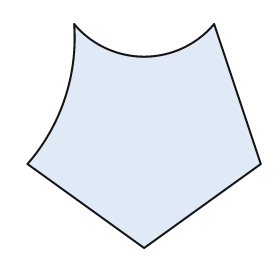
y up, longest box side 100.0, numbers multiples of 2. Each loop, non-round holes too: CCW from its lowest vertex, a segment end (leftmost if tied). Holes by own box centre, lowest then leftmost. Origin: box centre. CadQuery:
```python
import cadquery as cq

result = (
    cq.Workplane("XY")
    .moveTo(0.0, -48.0)
    .lineTo(50.0, -12.0)
    .lineTo(30.0, 48.0)
    .threePointArc((0.0, 34.0), (-30.0, 48.0))
    .threePointArc((-34.0, 16.0), (-50.0, -12.0))
    .close()
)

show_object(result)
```